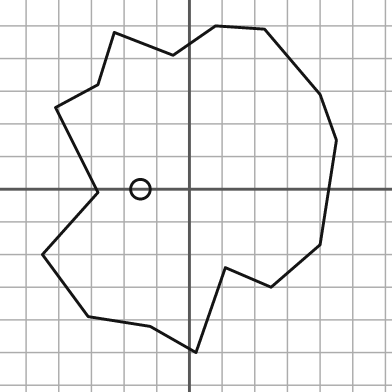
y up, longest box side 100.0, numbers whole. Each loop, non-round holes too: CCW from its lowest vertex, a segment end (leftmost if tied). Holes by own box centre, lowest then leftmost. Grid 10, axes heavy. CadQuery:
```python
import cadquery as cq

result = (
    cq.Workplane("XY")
    .moveTo(2.0, -50.0)
    .lineTo(11.0, -24.0)
    .lineTo(25.0, -30.0)
    .lineTo(40.0, -17.0)
    .lineTo(45.0, 15.0)
    .lineTo(40.0, 29.0)
    .lineTo(23.0, 49.0)
    .lineTo(8.0, 50.0)
    .lineTo(-5.0, 41.0)
    .lineTo(-23.0, 48.0)
    .lineTo(-28.0, 32.0)
    .lineTo(-41.0, 25.0)
    .lineTo(-28.0, -1.0)
    .lineTo(-45.0, -20.0)
    .lineTo(-31.0, -39.0)
    .lineTo(-12.0, -42.0)
    .close()
    .moveTo(-15.0, 0.0)
    .circle(3.0)
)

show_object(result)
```